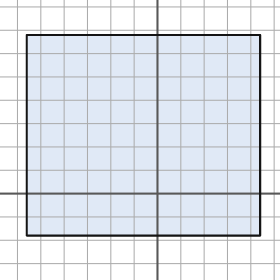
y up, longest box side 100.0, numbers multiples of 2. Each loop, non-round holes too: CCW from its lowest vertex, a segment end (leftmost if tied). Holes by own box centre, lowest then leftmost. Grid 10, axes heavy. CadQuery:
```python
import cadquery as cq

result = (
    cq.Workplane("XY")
    .moveTo(-56.0, -18.0)
    .lineTo(44.0, -18.0)
    .lineTo(44.0, 68.0)
    .lineTo(-56.0, 68.0)
    .close()
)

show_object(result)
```